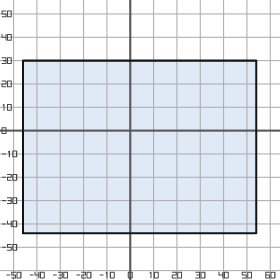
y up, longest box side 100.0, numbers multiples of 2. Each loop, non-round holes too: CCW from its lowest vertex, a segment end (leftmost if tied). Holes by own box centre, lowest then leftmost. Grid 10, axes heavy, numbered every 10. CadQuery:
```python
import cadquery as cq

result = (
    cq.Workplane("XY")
    .moveTo(-46.0, -44.0)
    .lineTo(54.0, -44.0)
    .lineTo(54.0, 30.0)
    .lineTo(-46.0, 30.0)
    .close()
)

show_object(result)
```